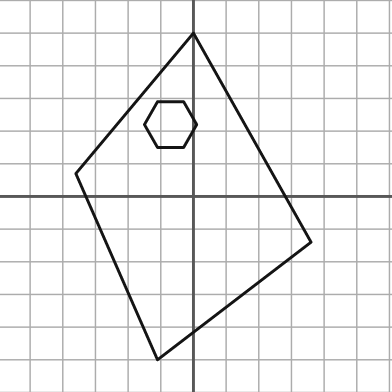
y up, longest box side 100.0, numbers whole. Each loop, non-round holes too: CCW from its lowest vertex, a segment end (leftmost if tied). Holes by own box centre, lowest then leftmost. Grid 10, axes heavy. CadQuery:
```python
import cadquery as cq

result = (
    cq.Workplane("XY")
    .moveTo(-11.0, -50.0)
    .lineTo(36.0, -14.0)
    .lineTo(0.0, 50.0)
    .lineTo(-36.0, 7.0)
    .close()
    .moveTo(-11.0, 15.0)
    .lineTo(-3.0, 15.0)
    .lineTo(1.0, 22.0)
    .lineTo(-3.0, 29.0)
    .lineTo(-11.0, 29.0)
    .lineTo(-15.0, 22.0)
    .close()
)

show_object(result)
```